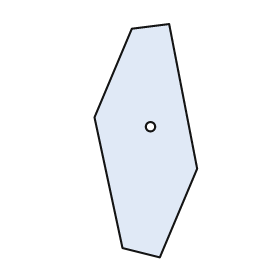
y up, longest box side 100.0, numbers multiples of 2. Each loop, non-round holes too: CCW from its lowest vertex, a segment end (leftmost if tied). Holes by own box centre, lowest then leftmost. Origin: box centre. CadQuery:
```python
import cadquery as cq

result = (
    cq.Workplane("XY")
    .moveTo(6.0, -50.0)
    .lineTo(22.0, -12.0)
    .lineTo(10.0, 50.0)
    .lineTo(-6.0, 48.0)
    .lineTo(-22.0, 10.0)
    .lineTo(-10.0, -46.0)
    .close()
    .moveTo(2.0, 6.0)
    .circle(2.0)
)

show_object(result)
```